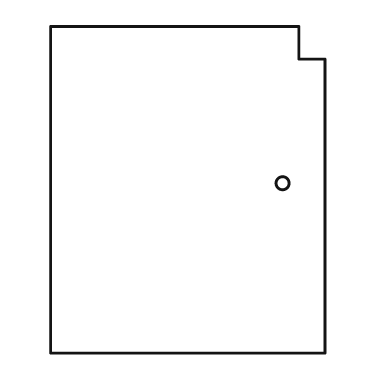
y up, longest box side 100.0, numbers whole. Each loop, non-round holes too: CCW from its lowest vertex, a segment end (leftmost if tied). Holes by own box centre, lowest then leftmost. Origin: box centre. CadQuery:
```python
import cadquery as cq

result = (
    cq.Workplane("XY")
    .moveTo(-42.0, -50.0)
    .lineTo(42.0, -50.0)
    .lineTo(42.0, 40.0)
    .lineTo(34.0, 40.0)
    .lineTo(34.0, 50.0)
    .lineTo(-42.0, 50.0)
    .close()
    .moveTo(29.0, 2.0)
    .circle(2.0)
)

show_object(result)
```